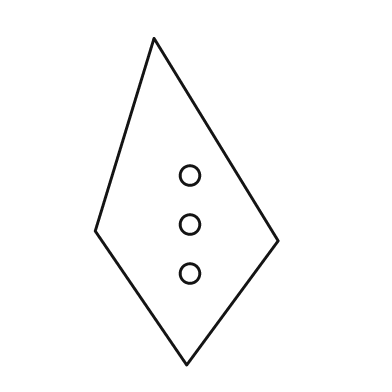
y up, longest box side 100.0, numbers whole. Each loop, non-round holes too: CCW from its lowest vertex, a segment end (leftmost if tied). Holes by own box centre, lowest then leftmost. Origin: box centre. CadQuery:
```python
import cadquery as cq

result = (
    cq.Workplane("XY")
    .moveTo(0.0, -50.0)
    .lineTo(28.0, -12.0)
    .lineTo(-10.0, 50.0)
    .lineTo(-28.0, -9.0)
    .close()
    .moveTo(1.0, -22.0)
    .circle(3.0)
    .moveTo(1.0, -7.0)
    .circle(3.0)
    .moveTo(1.0, 8.0)
    .circle(3.0)
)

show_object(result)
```